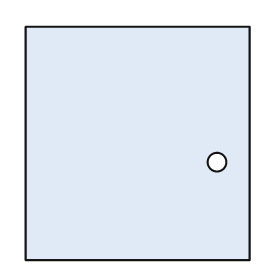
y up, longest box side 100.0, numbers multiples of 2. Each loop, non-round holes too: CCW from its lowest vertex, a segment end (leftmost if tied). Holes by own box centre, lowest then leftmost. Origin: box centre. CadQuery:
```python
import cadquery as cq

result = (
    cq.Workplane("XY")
    .moveTo(-48.0, -50.0)
    .lineTo(48.0, -50.0)
    .lineTo(48.0, 50.0)
    .lineTo(-48.0, 50.0)
    .close()
    .moveTo(34.0, -8.0)
    .circle(4.0)
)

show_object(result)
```